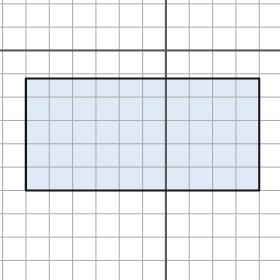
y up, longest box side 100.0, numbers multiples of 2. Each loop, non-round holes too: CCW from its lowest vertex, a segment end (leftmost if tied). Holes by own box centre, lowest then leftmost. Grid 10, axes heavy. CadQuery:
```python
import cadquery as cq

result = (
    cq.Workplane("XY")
    .moveTo(-60.0, -60.0)
    .lineTo(40.0, -60.0)
    .lineTo(40.0, -12.0)
    .lineTo(-60.0, -12.0)
    .close()
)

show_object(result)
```